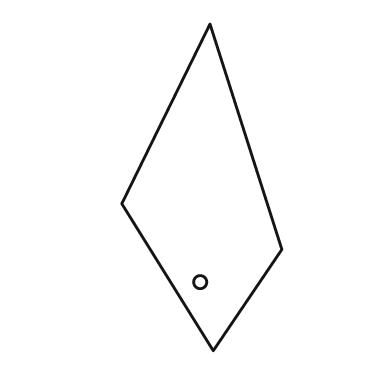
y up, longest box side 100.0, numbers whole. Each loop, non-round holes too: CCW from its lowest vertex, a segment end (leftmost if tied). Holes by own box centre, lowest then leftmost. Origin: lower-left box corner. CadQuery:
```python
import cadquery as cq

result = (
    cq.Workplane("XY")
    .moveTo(28.0, 0.0)
    .lineTo(49.0, 31.0)
    .lineTo(27.0, 100.0)
    .lineTo(0.0, 45.0)
    .close()
    .moveTo(24.0, 21.0)
    .circle(2.0)
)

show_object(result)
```